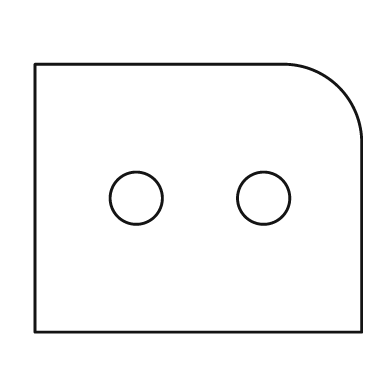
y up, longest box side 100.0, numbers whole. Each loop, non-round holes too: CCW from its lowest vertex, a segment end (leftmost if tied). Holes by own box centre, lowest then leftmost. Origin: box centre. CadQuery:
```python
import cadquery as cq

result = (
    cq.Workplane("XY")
    .moveTo(-50.0, -41.0)
    .lineTo(50.0, -41.0)
    .lineTo(50.0, 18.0)
    .threePointArc((43.0, 34.0), (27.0, 41.0))
    .lineTo(-50.0, 41.0)
    .close()
    .moveTo(-19.0, 0.0)
    .circle(8.0)
    .moveTo(20.0, 0.0)
    .circle(8.0)
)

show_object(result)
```